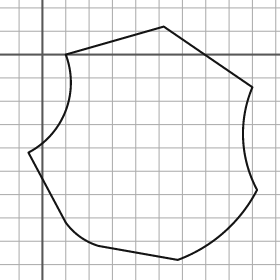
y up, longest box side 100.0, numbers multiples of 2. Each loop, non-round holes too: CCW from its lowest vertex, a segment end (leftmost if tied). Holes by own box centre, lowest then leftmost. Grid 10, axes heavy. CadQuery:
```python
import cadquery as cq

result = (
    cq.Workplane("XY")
    .moveTo(58.0, -88.0)
    .threePointArc((78.0, -76.0), (92.0, -58.0))
    .threePointArc((86.0, -36.0), (90.0, -14.0))
    .lineTo(52.0, 12.0)
    .lineTo(10.0, 0.0)
    .threePointArc((10.0, -24.0), (-6.0, -42.0))
    .lineTo(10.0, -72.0)
    .threePointArc((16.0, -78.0), (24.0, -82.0))
    .close()
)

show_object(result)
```